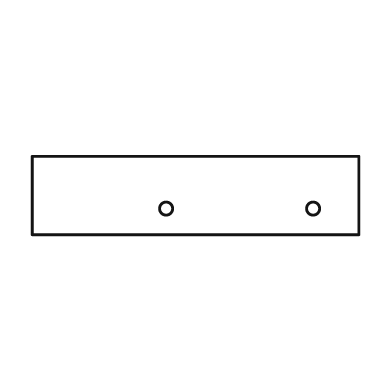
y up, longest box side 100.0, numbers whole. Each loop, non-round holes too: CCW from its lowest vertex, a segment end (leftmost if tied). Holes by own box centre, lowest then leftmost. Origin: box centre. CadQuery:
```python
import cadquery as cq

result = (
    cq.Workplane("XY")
    .moveTo(-50.0, -12.0)
    .lineTo(50.0, -12.0)
    .lineTo(50.0, 12.0)
    .lineTo(-50.0, 12.0)
    .close()
    .moveTo(-9.0, -4.0)
    .circle(2.0)
    .moveTo(36.0, -4.0)
    .circle(2.0)
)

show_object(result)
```